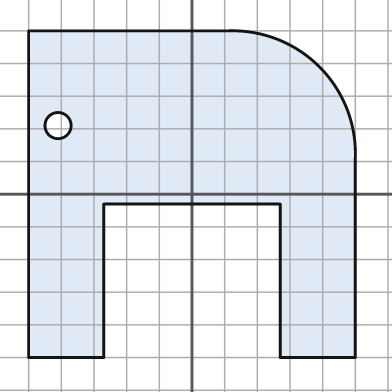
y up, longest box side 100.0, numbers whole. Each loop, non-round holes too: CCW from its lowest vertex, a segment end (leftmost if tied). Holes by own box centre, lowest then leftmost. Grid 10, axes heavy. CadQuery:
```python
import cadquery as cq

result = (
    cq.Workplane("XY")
    .moveTo(-50.0, -50.0)
    .lineTo(-27.0, -50.0)
    .lineTo(-27.0, -3.0)
    .lineTo(27.0, -3.0)
    .lineTo(27.0, -50.0)
    .lineTo(50.0, -50.0)
    .lineTo(50.0, 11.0)
    .threePointArc((39.0, 39.0), (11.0, 50.0))
    .lineTo(-50.0, 50.0)
    .close()
    .moveTo(-41.0, 21.0)
    .circle(4.0)
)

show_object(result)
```